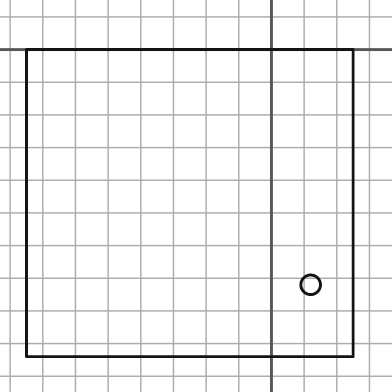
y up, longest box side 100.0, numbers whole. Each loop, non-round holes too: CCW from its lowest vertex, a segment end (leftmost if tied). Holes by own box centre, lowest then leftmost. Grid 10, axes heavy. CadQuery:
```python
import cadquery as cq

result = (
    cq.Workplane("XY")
    .moveTo(-75.0, -94.0)
    .lineTo(25.0, -94.0)
    .lineTo(25.0, 0.0)
    .lineTo(-75.0, 0.0)
    .close()
    .moveTo(12.0, -72.0)
    .circle(3.0)
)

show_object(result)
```